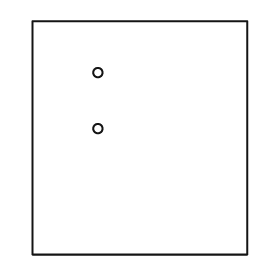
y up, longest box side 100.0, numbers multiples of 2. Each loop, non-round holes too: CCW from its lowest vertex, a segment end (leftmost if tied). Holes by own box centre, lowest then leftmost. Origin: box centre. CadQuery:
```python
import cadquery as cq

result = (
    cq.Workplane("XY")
    .moveTo(-46.0, -50.0)
    .lineTo(46.0, -50.0)
    .lineTo(46.0, 50.0)
    .lineTo(-46.0, 50.0)
    .close()
    .moveTo(-18.0, 4.0)
    .circle(2.0)
    .moveTo(-18.0, 28.0)
    .circle(2.0)
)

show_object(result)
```